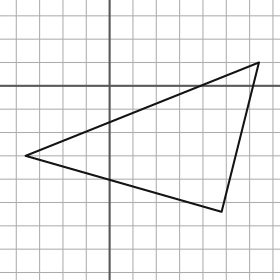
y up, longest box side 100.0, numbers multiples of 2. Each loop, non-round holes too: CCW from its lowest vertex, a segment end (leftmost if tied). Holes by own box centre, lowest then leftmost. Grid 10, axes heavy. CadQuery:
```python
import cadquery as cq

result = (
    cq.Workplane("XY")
    .moveTo(48.0, -54.0)
    .lineTo(64.0, 10.0)
    .lineTo(-36.0, -30.0)
    .close()
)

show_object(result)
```